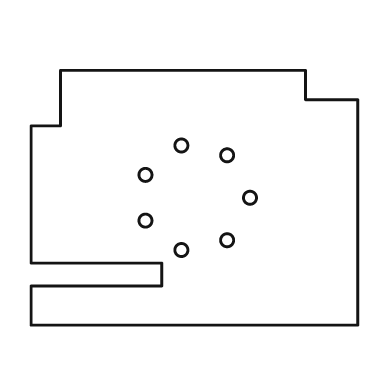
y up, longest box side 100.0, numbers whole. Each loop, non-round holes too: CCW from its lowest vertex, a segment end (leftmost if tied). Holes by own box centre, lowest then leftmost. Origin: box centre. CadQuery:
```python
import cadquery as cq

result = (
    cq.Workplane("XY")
    .moveTo(-50.0, -39.0)
    .lineTo(50.0, -39.0)
    .lineTo(50.0, 30.0)
    .lineTo(34.0, 30.0)
    .lineTo(34.0, 39.0)
    .lineTo(-41.0, 39.0)
    .lineTo(-41.0, 22.0)
    .lineTo(-50.0, 22.0)
    .lineTo(-50.0, -20.0)
    .lineTo(-10.0, -20.0)
    .lineTo(-10.0, -27.0)
    .lineTo(-50.0, -27.0)
    .close()
    .moveTo(-4.0, -16.0)
    .circle(2.0)
    .moveTo(10.0, -13.0)
    .circle(2.0)
    .moveTo(-15.0, -7.0)
    .circle(2.0)
    .moveTo(17.0, 0.0)
    .circle(2.0)
    .moveTo(-15.0, 7.0)
    .circle(2.0)
    .moveTo(10.0, 13.0)
    .circle(2.0)
    .moveTo(-4.0, 16.0)
    .circle(2.0)
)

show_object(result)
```